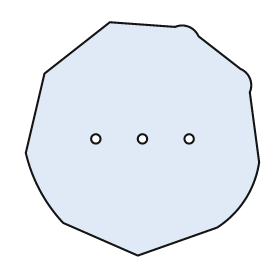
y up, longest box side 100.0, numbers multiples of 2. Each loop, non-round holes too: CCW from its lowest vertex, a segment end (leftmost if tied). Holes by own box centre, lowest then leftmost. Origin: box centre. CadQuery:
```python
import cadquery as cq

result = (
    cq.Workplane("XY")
    .moveTo(-2.0, -50.0)
    .lineTo(32.0, -38.0)
    .threePointArc((44.0, -26.0), (50.0, -10.0))
    .lineTo(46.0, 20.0)
    .threePointArc((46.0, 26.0), (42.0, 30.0))
    .lineTo(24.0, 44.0)
    .threePointArc((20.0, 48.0), (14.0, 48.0))
    .lineTo(-14.0, 50.0)
    .lineTo(-42.0, 28.0)
    .lineTo(-50.0, -6.0)
    .threePointArc((-44.0, -22.0), (-34.0, -36.0))
    .close()
    .moveTo(-20.0, 0.0)
    .circle(2.0)
    .moveTo(0.0, 0.0)
    .circle(2.0)
    .moveTo(20.0, 0.0)
    .circle(2.0)
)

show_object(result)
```